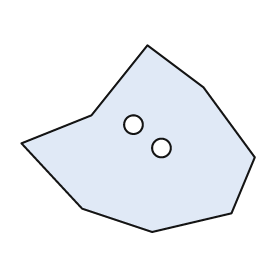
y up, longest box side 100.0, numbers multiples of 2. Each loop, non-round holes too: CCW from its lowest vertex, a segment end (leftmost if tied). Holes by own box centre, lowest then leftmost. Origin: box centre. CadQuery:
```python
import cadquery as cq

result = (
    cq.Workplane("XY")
    .moveTo(6.0, -40.0)
    .lineTo(40.0, -32.0)
    .lineTo(50.0, -8.0)
    .lineTo(28.0, 22.0)
    .lineTo(4.0, 40.0)
    .lineTo(-20.0, 10.0)
    .lineTo(-50.0, -2.0)
    .lineTo(-24.0, -30.0)
    .close()
    .moveTo(10.0, -4.0)
    .circle(4.0)
    .moveTo(-2.0, 6.0)
    .circle(4.0)
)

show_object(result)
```